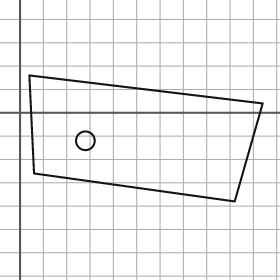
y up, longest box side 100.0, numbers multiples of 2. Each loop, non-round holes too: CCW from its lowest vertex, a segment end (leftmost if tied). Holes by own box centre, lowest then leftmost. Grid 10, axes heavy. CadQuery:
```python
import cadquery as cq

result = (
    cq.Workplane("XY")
    .moveTo(92.0, -38.0)
    .lineTo(104.0, 4.0)
    .lineTo(4.0, 16.0)
    .lineTo(6.0, -26.0)
    .close()
    .moveTo(28.0, -12.0)
    .circle(4.0)
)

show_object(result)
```